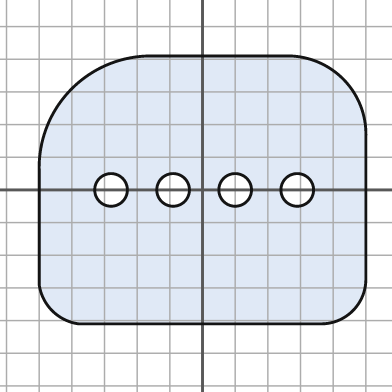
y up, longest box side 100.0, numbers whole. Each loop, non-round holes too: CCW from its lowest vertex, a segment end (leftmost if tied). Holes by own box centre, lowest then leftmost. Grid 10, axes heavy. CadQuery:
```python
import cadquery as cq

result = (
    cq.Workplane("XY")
    .moveTo(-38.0, -41.0)
    .lineTo(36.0, -41.0)
    .threePointArc((46.0, -37.0), (50.0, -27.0))
    .lineTo(50.0, 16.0)
    .threePointArc((43.0, 34.0), (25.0, 41.0))
    .lineTo(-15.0, 41.0)
    .threePointArc((-40.0, 31.0), (-50.0, 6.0))
    .lineTo(-50.0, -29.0)
    .threePointArc((-46.0, -37.0), (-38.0, -41.0))
    .close()
    .moveTo(-28.0, 0.0)
    .circle(5.0)
    .moveTo(-9.0, 0.0)
    .circle(5.0)
    .moveTo(10.0, 0.0)
    .circle(5.0)
    .moveTo(29.0, 0.0)
    .circle(5.0)
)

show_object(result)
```